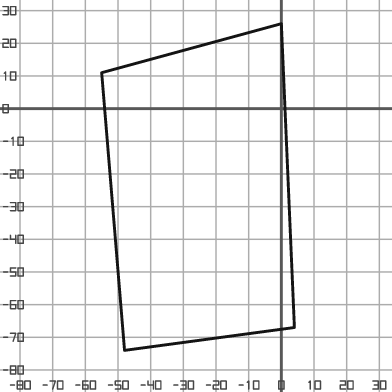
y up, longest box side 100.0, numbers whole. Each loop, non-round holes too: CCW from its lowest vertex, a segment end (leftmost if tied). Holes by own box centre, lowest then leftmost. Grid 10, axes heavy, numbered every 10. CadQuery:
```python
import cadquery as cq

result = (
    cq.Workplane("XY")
    .moveTo(-48.0, -74.0)
    .lineTo(4.0, -67.0)
    .lineTo(0.0, 26.0)
    .lineTo(-55.0, 11.0)
    .close()
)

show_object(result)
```